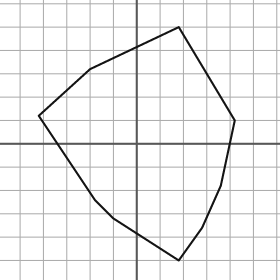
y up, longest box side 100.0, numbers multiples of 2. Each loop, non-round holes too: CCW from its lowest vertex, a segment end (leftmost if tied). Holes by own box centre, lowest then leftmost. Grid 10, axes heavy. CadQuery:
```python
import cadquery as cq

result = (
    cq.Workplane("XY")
    .moveTo(18.0, -50.0)
    .lineTo(28.0, -36.0)
    .lineTo(36.0, -18.0)
    .lineTo(42.0, 10.0)
    .lineTo(18.0, 50.0)
    .lineTo(-20.0, 32.0)
    .lineTo(-42.0, 12.0)
    .lineTo(-18.0, -24.0)
    .lineTo(-10.0, -32.0)
    .close()
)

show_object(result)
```